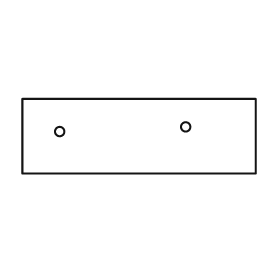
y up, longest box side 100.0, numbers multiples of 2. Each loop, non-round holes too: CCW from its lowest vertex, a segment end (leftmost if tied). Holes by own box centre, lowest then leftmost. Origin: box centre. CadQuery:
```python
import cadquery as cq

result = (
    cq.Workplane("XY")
    .moveTo(-50.0, -16.0)
    .lineTo(50.0, -16.0)
    .lineTo(50.0, 16.0)
    .lineTo(-50.0, 16.0)
    .close()
    .moveTo(-34.0, 2.0)
    .circle(2.0)
    .moveTo(20.0, 4.0)
    .circle(2.0)
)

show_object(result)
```